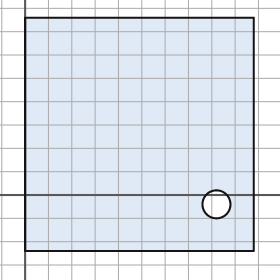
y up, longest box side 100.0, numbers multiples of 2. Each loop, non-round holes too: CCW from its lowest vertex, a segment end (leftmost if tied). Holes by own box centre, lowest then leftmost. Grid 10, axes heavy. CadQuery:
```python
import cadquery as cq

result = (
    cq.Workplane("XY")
    .moveTo(0.0, -24.0)
    .lineTo(98.0, -24.0)
    .lineTo(98.0, 76.0)
    .lineTo(0.0, 76.0)
    .close()
    .moveTo(82.0, -4.0)
    .circle(6.0)
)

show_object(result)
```